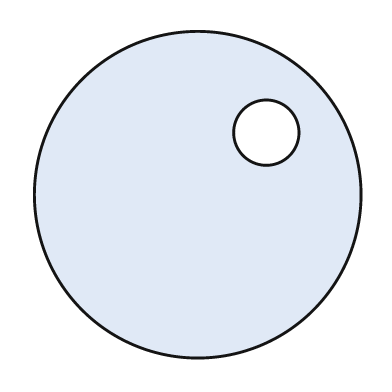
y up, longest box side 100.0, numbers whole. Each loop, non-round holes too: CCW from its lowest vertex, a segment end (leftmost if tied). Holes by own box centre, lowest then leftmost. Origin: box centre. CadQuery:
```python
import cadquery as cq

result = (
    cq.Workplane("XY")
    .moveTo(0.0, 0.0)
    .circle(50.0)
    .moveTo(21.0, 19.0)
    .circle(10.0)
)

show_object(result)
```